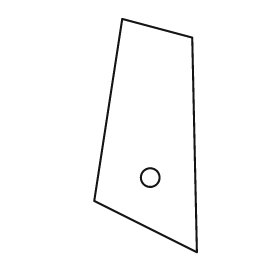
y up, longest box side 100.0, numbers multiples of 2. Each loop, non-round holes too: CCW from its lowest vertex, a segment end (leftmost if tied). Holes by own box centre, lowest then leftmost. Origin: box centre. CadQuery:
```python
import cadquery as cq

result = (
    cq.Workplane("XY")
    .moveTo(22.0, -50.0)
    .lineTo(20.0, 42.0)
    .lineTo(-10.0, 50.0)
    .lineTo(-22.0, -28.0)
    .close()
    .moveTo(2.0, -18.0)
    .circle(4.0)
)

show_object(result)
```